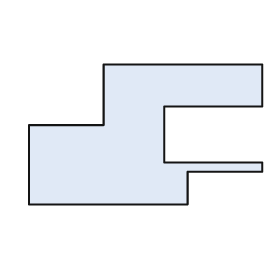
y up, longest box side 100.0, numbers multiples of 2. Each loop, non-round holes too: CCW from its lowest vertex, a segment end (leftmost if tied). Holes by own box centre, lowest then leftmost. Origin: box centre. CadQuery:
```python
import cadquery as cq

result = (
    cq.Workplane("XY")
    .moveTo(-50.0, -30.0)
    .lineTo(18.0, -30.0)
    .lineTo(18.0, -16.0)
    .lineTo(50.0, -16.0)
    .lineTo(50.0, -12.0)
    .lineTo(8.0, -12.0)
    .lineTo(8.0, 12.0)
    .lineTo(50.0, 12.0)
    .lineTo(50.0, 30.0)
    .lineTo(-18.0, 30.0)
    .lineTo(-18.0, 4.0)
    .lineTo(-50.0, 4.0)
    .close()
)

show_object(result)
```